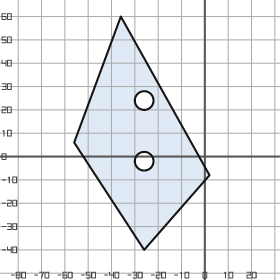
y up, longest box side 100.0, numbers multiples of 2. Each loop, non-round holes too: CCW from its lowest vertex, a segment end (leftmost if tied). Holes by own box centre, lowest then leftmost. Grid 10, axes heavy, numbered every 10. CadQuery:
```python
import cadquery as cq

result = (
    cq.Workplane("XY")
    .moveTo(-26.0, -40.0)
    .lineTo(2.0, -8.0)
    .lineTo(-36.0, 60.0)
    .lineTo(-56.0, 6.0)
    .close()
    .moveTo(-26.0, -2.0)
    .circle(4.0)
    .moveTo(-26.0, 24.0)
    .circle(4.0)
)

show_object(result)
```